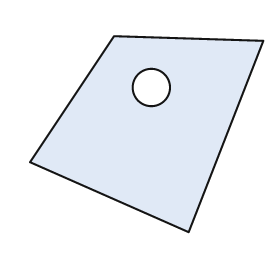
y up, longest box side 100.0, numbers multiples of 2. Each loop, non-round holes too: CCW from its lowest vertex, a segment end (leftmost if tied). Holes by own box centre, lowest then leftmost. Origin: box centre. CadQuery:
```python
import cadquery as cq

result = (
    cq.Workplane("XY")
    .moveTo(18.0, -42.0)
    .lineTo(50.0, 40.0)
    .lineTo(-14.0, 42.0)
    .lineTo(-50.0, -12.0)
    .close()
    .moveTo(2.0, 20.0)
    .circle(8.0)
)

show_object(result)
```